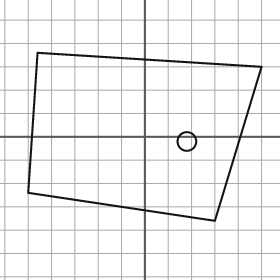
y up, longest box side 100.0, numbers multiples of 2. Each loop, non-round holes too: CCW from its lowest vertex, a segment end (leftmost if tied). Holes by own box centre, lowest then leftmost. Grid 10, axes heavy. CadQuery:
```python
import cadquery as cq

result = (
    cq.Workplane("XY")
    .moveTo(30.0, -36.0)
    .lineTo(50.0, 30.0)
    .lineTo(-46.0, 36.0)
    .lineTo(-50.0, -24.0)
    .close()
    .moveTo(18.0, -2.0)
    .circle(4.0)
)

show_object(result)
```